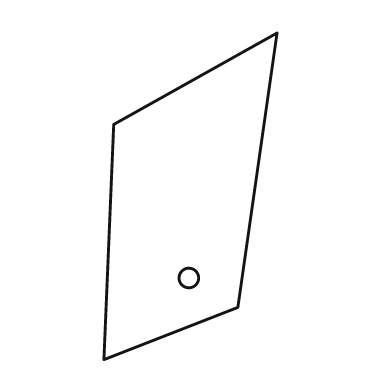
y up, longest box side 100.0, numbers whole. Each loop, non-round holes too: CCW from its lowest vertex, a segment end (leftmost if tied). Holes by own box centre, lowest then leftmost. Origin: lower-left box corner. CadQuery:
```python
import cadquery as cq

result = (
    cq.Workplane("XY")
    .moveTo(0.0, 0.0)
    .lineTo(41.0, 16.0)
    .lineTo(53.0, 100.0)
    .lineTo(3.0, 72.0)
    .close()
    .moveTo(26.0, 25.0)
    .circle(3.0)
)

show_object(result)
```